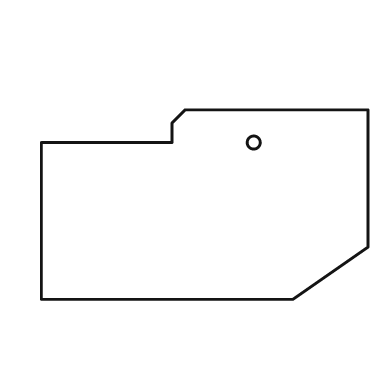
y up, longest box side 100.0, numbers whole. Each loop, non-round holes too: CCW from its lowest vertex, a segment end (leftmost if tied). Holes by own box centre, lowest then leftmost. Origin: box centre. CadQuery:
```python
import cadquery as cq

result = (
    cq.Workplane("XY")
    .moveTo(-50.0, -29.0)
    .lineTo(27.0, -29.0)
    .lineTo(50.0, -13.0)
    .lineTo(50.0, 29.0)
    .lineTo(-6.0, 29.0)
    .lineTo(-10.0, 25.0)
    .lineTo(-10.0, 19.0)
    .lineTo(-50.0, 19.0)
    .close()
    .moveTo(15.0, 19.0)
    .circle(2.0)
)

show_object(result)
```